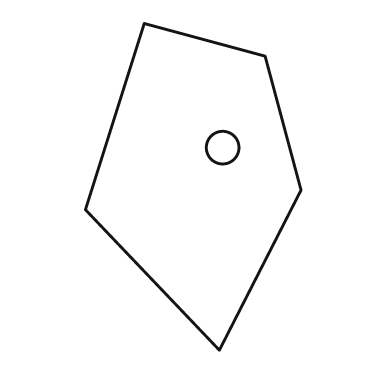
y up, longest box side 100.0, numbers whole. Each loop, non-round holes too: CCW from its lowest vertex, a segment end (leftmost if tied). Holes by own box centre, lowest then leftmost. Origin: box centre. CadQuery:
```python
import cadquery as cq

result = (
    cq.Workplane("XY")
    .moveTo(8.0, -50.0)
    .lineTo(33.0, -1.0)
    .lineTo(22.0, 40.0)
    .lineTo(-15.0, 50.0)
    .lineTo(-33.0, -7.0)
    .close()
    .moveTo(9.0, 12.0)
    .circle(5.0)
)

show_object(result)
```